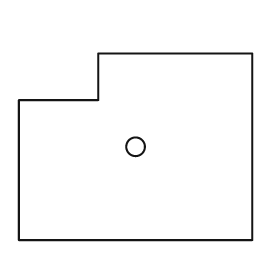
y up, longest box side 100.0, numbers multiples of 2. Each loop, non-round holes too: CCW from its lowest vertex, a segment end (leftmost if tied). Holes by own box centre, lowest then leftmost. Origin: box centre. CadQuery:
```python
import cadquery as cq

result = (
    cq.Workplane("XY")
    .moveTo(-50.0, -40.0)
    .lineTo(50.0, -40.0)
    .lineTo(50.0, 40.0)
    .lineTo(-16.0, 40.0)
    .lineTo(-16.0, 20.0)
    .lineTo(-50.0, 20.0)
    .close()
    .moveTo(0.0, 0.0)
    .circle(4.0)
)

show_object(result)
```